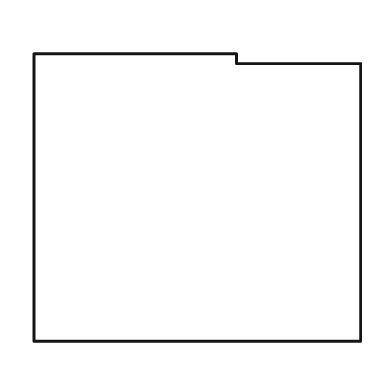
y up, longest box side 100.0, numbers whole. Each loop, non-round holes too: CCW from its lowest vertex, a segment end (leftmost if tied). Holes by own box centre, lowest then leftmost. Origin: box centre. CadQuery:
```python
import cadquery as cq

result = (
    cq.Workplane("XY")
    .moveTo(-50.0, -44.0)
    .lineTo(50.0, -44.0)
    .lineTo(50.0, 41.0)
    .lineTo(12.0, 41.0)
    .lineTo(12.0, 44.0)
    .lineTo(-50.0, 44.0)
    .close()
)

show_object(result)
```